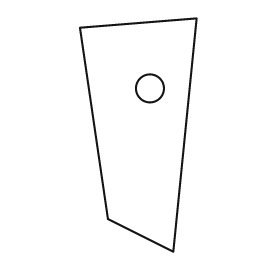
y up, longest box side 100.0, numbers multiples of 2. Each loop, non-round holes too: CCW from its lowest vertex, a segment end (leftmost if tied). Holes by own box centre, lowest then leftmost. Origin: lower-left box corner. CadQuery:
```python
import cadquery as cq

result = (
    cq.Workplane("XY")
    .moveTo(40.0, 0.0)
    .lineTo(50.0, 100.0)
    .lineTo(0.0, 96.0)
    .lineTo(12.0, 14.0)
    .close()
    .moveTo(30.0, 70.0)
    .circle(6.0)
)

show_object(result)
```